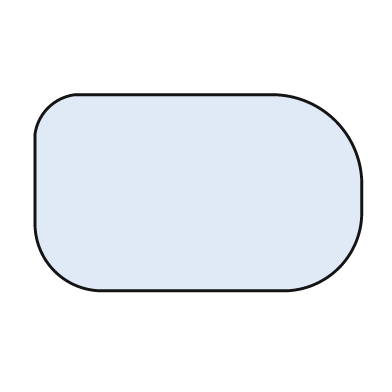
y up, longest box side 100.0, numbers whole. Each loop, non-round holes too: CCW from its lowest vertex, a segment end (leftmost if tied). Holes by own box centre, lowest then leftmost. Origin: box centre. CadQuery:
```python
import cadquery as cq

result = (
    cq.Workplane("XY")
    .moveTo(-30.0, -30.0)
    .lineTo(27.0, -30.0)
    .threePointArc((43.0, -23.0), (50.0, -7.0))
    .lineTo(50.0, 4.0)
    .threePointArc((42.0, 22.0), (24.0, 30.0))
    .lineTo(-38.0, 30.0)
    .threePointArc((-46.0, 26.0), (-50.0, 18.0))
    .lineTo(-50.0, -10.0)
    .threePointArc((-44.0, -24.0), (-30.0, -30.0))
    .close()
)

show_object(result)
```